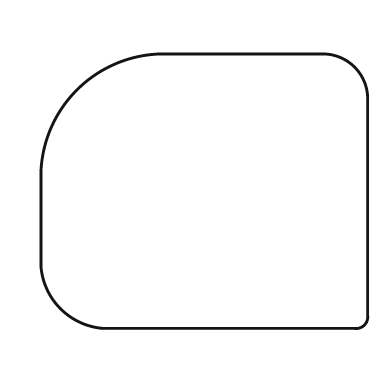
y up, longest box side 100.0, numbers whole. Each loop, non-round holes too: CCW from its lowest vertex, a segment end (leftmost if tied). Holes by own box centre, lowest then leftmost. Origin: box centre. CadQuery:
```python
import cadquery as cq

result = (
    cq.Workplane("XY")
    .moveTo(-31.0, -42.0)
    .lineTo(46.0, -42.0)
    .threePointArc((49.0, -41.0), (50.0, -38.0))
    .lineTo(50.0, 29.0)
    .threePointArc((46.0, 38.0), (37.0, 42.0))
    .lineTo(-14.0, 42.0)
    .threePointArc((-39.0, 31.0), (-50.0, 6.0))
    .lineTo(-50.0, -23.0)
    .threePointArc((-44.0, -36.0), (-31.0, -42.0))
    .close()
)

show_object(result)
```